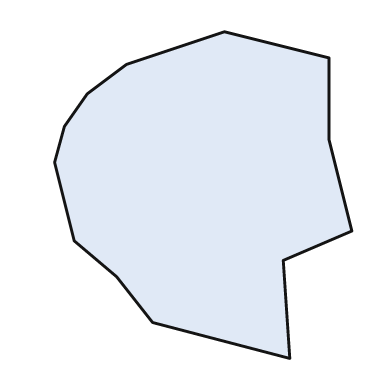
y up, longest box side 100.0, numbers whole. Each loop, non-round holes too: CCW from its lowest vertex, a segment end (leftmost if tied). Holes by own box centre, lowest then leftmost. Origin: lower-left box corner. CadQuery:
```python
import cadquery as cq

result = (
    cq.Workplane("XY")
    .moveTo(72.0, 0.0)
    .lineTo(70.0, 30.0)
    .lineTo(91.0, 39.0)
    .lineTo(84.0, 67.0)
    .lineTo(84.0, 92.0)
    .lineTo(52.0, 100.0)
    .lineTo(22.0, 90.0)
    .lineTo(10.0, 81.0)
    .lineTo(3.0, 71.0)
    .lineTo(0.0, 60.0)
    .lineTo(6.0, 36.0)
    .lineTo(19.0, 25.0)
    .lineTo(30.0, 11.0)
    .close()
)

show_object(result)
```